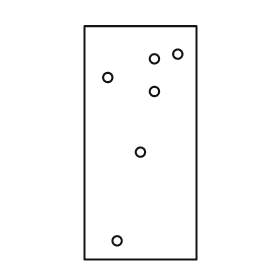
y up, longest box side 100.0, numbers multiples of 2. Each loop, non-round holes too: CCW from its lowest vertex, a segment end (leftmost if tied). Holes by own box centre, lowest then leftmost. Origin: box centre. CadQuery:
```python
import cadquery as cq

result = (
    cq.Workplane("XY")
    .moveTo(-24.0, -50.0)
    .lineTo(24.0, -50.0)
    .lineTo(24.0, 50.0)
    .lineTo(-24.0, 50.0)
    .close()
    .moveTo(-10.0, -42.0)
    .circle(2.0)
    .moveTo(0.0, -4.0)
    .circle(2.0)
    .moveTo(6.0, 22.0)
    .circle(2.0)
    .moveTo(-14.0, 28.0)
    .circle(2.0)
    .moveTo(6.0, 36.0)
    .circle(2.0)
    .moveTo(16.0, 38.0)
    .circle(2.0)
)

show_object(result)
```